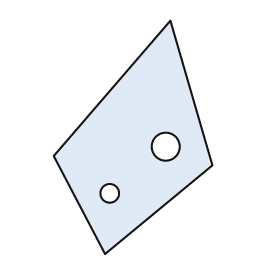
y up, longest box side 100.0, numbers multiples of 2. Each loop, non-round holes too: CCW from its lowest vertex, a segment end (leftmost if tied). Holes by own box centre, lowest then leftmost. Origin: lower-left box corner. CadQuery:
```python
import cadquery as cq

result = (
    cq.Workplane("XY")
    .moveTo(22.0, 0.0)
    .lineTo(68.0, 38.0)
    .lineTo(50.0, 100.0)
    .lineTo(0.0, 42.0)
    .close()
    .moveTo(24.0, 26.0)
    .circle(4.0)
    .moveTo(48.0, 46.0)
    .circle(6.0)
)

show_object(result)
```